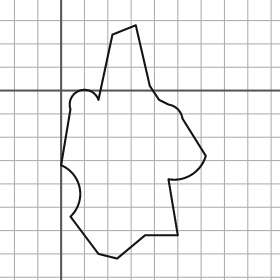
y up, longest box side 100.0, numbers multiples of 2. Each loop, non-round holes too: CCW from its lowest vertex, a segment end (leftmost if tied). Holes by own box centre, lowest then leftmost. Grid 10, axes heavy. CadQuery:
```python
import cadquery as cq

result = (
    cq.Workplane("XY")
    .moveTo(24.0, -72.0)
    .lineTo(36.0, -62.0)
    .lineTo(50.0, -62.0)
    .lineTo(46.0, -38.0)
    .threePointArc((56.0, -36.0), (62.0, -28.0))
    .lineTo(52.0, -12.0)
    .threePointArc((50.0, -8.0), (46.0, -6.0))
    .lineTo(42.0, -4.0)
    .lineTo(38.0, 2.0)
    .lineTo(32.0, 28.0)
    .lineTo(22.0, 24.0)
    .lineTo(16.0, -4.0)
    .threePointArc((8.0, 0.0), (4.0, -8.0))
    .lineTo(0.0, -32.0)
    .threePointArc((8.0, -42.0), (4.0, -54.0))
    .lineTo(16.0, -70.0)
    .close()
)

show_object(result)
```